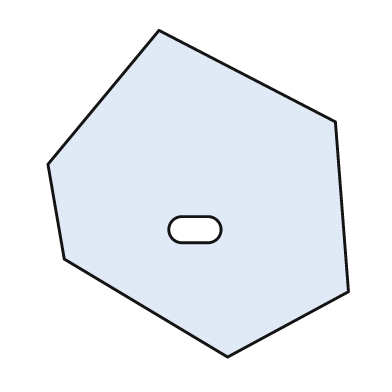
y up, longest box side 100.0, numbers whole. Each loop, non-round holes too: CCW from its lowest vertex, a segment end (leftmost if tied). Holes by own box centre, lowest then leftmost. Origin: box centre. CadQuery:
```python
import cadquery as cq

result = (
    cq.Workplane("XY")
    .moveTo(9.0, -50.0)
    .lineTo(46.0, -30.0)
    .lineTo(42.0, 22.0)
    .lineTo(-12.0, 50.0)
    .lineTo(-46.0, 9.0)
    .lineTo(-41.0, -20.0)
    .close()
    .moveTo(-5.0, -15.0)
    .lineTo(3.0, -15.0)
    .threePointArc((7.0, -11.0), (3.0, -7.0))
    .lineTo(-5.0, -7.0)
    .threePointArc((-9.0, -11.0), (-5.0, -15.0))
    .close()
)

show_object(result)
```